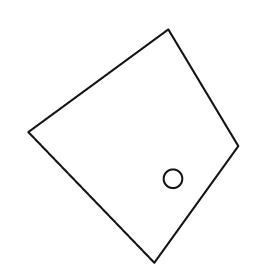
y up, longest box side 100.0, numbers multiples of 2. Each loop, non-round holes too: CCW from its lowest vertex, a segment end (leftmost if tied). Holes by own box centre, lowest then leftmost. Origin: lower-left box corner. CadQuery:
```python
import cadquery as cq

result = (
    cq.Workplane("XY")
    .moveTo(54.0, 0.0)
    .lineTo(90.0, 50.0)
    .lineTo(60.0, 100.0)
    .lineTo(0.0, 56.0)
    .close()
    .moveTo(62.0, 36.0)
    .circle(4.0)
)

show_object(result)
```